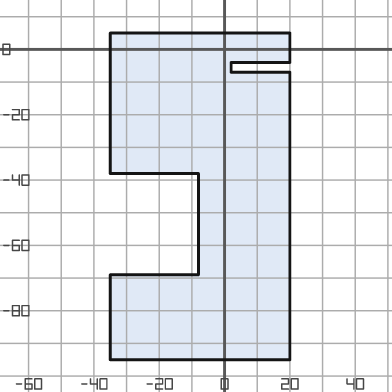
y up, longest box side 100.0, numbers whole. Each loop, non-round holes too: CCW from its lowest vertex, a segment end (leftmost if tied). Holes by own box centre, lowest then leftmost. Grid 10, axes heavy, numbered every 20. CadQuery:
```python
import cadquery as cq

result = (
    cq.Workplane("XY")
    .moveTo(-35.0, -95.0)
    .lineTo(20.0, -95.0)
    .lineTo(20.0, -7.0)
    .lineTo(2.0, -7.0)
    .lineTo(2.0, -4.0)
    .lineTo(20.0, -4.0)
    .lineTo(20.0, 5.0)
    .lineTo(-35.0, 5.0)
    .lineTo(-35.0, -38.0)
    .lineTo(-8.0, -38.0)
    .lineTo(-8.0, -69.0)
    .lineTo(-35.0, -69.0)
    .close()
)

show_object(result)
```